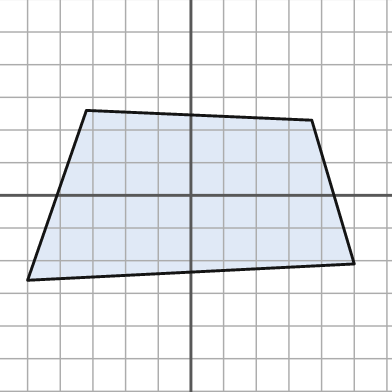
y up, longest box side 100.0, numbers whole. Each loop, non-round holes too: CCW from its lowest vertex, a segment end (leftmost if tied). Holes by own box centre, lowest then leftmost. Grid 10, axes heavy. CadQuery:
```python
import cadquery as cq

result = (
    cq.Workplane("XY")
    .moveTo(-50.0, -26.0)
    .lineTo(50.0, -21.0)
    .lineTo(37.0, 23.0)
    .lineTo(-32.0, 26.0)
    .close()
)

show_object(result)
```